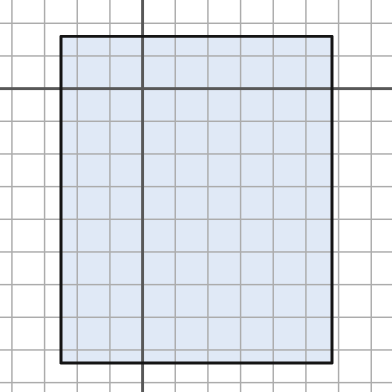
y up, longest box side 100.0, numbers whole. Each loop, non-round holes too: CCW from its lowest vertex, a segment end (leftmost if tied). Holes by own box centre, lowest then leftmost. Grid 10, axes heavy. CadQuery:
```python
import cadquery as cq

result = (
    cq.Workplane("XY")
    .moveTo(-25.0, -84.0)
    .lineTo(58.0, -84.0)
    .lineTo(58.0, 16.0)
    .lineTo(-25.0, 16.0)
    .close()
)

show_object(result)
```